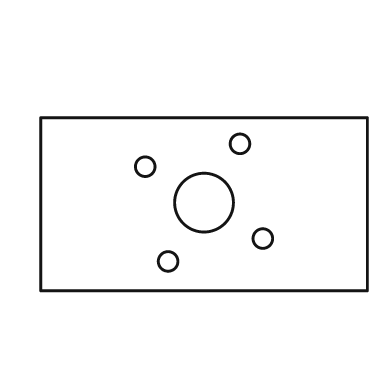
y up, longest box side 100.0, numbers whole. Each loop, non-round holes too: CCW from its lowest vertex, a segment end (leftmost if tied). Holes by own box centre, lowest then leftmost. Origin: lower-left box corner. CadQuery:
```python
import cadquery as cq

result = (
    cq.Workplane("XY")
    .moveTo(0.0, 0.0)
    .lineTo(100.0, 0.0)
    .lineTo(100.0, 53.0)
    .lineTo(0.0, 53.0)
    .close()
    .moveTo(39.0, 9.0)
    .circle(3.0)
    .moveTo(68.0, 16.0)
    .circle(3.0)
    .moveTo(50.0, 27.0)
    .circle(9.0)
    .moveTo(32.0, 38.0)
    .circle(3.0)
    .moveTo(61.0, 45.0)
    .circle(3.0)
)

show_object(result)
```